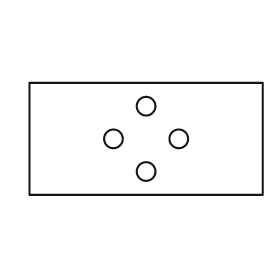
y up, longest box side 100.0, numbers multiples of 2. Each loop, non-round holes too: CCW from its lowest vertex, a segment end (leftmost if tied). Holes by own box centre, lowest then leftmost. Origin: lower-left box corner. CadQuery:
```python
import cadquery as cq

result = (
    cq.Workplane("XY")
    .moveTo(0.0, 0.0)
    .lineTo(100.0, 0.0)
    .lineTo(100.0, 48.0)
    .lineTo(0.0, 48.0)
    .close()
    .moveTo(50.0, 10.0)
    .circle(4.0)
    .moveTo(36.0, 24.0)
    .circle(4.0)
    .moveTo(64.0, 24.0)
    .circle(4.0)
    .moveTo(50.0, 38.0)
    .circle(4.0)
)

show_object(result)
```